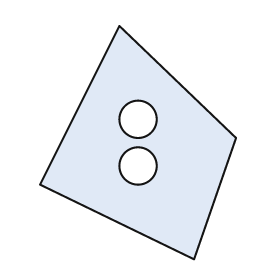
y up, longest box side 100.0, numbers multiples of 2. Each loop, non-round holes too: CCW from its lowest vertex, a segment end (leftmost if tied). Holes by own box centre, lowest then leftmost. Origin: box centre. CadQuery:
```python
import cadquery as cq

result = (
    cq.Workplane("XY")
    .moveTo(24.0, -50.0)
    .lineTo(42.0, 2.0)
    .lineTo(-8.0, 50.0)
    .lineTo(-42.0, -18.0)
    .close()
    .moveTo(0.0, -10.0)
    .circle(8.0)
    .moveTo(0.0, 10.0)
    .circle(8.0)
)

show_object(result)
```